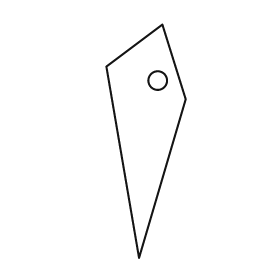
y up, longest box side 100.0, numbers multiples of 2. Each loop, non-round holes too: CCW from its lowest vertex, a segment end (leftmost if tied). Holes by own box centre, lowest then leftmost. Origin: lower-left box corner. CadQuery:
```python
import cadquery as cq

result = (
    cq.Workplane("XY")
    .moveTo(14.0, 0.0)
    .lineTo(34.0, 68.0)
    .lineTo(24.0, 100.0)
    .lineTo(0.0, 82.0)
    .close()
    .moveTo(22.0, 76.0)
    .circle(4.0)
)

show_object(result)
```